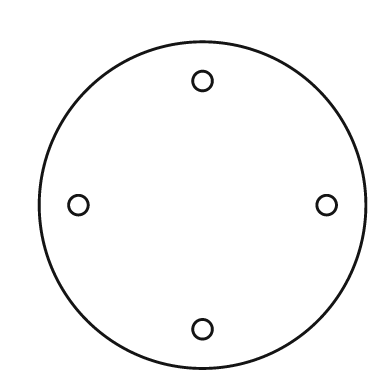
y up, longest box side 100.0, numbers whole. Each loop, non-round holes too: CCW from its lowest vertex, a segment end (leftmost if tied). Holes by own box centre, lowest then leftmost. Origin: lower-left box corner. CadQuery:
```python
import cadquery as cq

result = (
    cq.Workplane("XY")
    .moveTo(50.0, 50.0)
    .circle(50.0)
    .moveTo(50.0, 12.0)
    .circle(3.0)
    .moveTo(12.0, 50.0)
    .circle(3.0)
    .moveTo(88.0, 50.0)
    .circle(3.0)
    .moveTo(50.0, 88.0)
    .circle(3.0)
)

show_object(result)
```